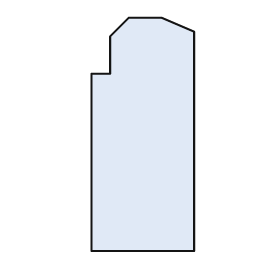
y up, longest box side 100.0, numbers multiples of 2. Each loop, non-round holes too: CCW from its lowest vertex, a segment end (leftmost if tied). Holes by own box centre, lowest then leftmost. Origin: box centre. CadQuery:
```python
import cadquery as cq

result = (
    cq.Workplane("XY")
    .moveTo(-22.0, -50.0)
    .lineTo(22.0, -50.0)
    .lineTo(22.0, 44.0)
    .lineTo(8.0, 50.0)
    .lineTo(-6.0, 50.0)
    .lineTo(-14.0, 42.0)
    .lineTo(-14.0, 26.0)
    .lineTo(-22.0, 26.0)
    .close()
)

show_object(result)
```